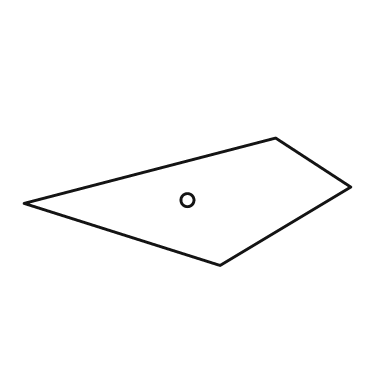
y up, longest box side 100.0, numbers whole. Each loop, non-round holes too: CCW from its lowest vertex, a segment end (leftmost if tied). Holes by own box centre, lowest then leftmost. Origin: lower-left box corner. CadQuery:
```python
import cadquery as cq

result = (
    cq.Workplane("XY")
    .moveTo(60.0, 0.0)
    .lineTo(100.0, 24.0)
    .lineTo(77.0, 39.0)
    .lineTo(0.0, 19.0)
    .close()
    .moveTo(50.0, 20.0)
    .circle(2.0)
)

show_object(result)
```